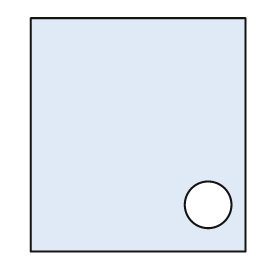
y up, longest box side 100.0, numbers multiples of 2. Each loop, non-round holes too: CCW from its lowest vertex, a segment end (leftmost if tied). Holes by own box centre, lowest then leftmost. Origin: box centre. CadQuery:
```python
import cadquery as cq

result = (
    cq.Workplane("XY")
    .moveTo(-46.0, -50.0)
    .lineTo(46.0, -50.0)
    .lineTo(46.0, 50.0)
    .lineTo(-46.0, 50.0)
    .close()
    .moveTo(30.0, -30.0)
    .circle(10.0)
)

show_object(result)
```